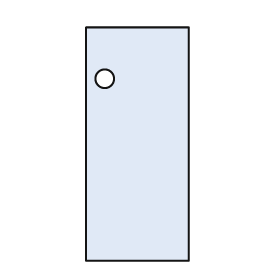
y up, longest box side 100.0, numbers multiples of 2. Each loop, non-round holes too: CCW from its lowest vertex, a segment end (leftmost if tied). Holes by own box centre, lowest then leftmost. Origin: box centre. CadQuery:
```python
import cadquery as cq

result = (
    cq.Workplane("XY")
    .moveTo(-22.0, -50.0)
    .lineTo(22.0, -50.0)
    .lineTo(22.0, 50.0)
    .lineTo(-22.0, 50.0)
    .close()
    .moveTo(-14.0, 28.0)
    .circle(4.0)
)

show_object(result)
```